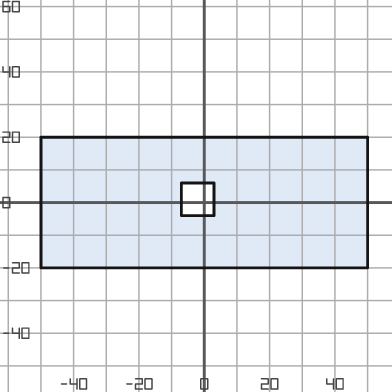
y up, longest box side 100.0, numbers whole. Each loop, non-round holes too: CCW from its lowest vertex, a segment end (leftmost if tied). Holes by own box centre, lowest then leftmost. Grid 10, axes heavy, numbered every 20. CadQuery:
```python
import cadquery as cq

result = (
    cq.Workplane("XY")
    .moveTo(-50.0, -20.0)
    .lineTo(50.0, -20.0)
    .lineTo(50.0, 20.0)
    .lineTo(-50.0, 20.0)
    .close()
    .moveTo(-7.0, -4.0)
    .lineTo(3.0, -4.0)
    .lineTo(3.0, 6.0)
    .lineTo(-7.0, 6.0)
    .close()
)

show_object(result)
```